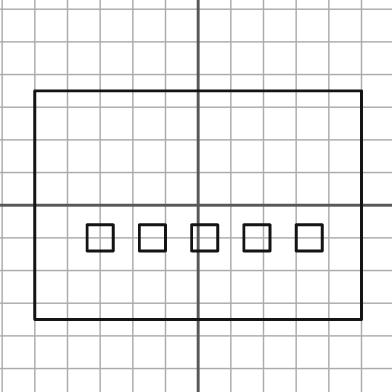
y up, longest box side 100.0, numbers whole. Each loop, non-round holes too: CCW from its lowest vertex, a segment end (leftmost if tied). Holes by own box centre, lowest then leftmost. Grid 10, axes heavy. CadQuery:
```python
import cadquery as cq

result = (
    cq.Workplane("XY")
    .moveTo(-50.0, -35.0)
    .lineTo(50.0, -35.0)
    .lineTo(50.0, 35.0)
    .lineTo(-50.0, 35.0)
    .close()
    .moveTo(-34.0, -14.0)
    .lineTo(-26.0, -14.0)
    .lineTo(-26.0, -6.0)
    .lineTo(-34.0, -6.0)
    .close()
    .moveTo(-18.0, -14.0)
    .lineTo(-10.0, -14.0)
    .lineTo(-10.0, -6.0)
    .lineTo(-18.0, -6.0)
    .close()
    .moveTo(-2.0, -14.0)
    .lineTo(6.0, -14.0)
    .lineTo(6.0, -6.0)
    .lineTo(-2.0, -6.0)
    .close()
    .moveTo(14.0, -14.0)
    .lineTo(22.0, -14.0)
    .lineTo(22.0, -6.0)
    .lineTo(14.0, -6.0)
    .close()
    .moveTo(30.0, -14.0)
    .lineTo(38.0, -14.0)
    .lineTo(38.0, -6.0)
    .lineTo(30.0, -6.0)
    .close()
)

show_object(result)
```